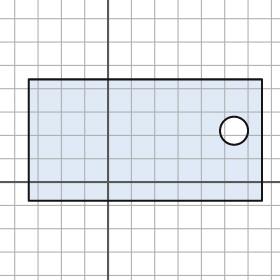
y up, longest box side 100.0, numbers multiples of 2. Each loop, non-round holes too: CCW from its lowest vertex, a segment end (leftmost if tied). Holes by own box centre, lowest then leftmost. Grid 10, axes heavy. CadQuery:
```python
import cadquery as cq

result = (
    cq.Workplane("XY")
    .moveTo(-34.0, -8.0)
    .lineTo(66.0, -8.0)
    .lineTo(66.0, 44.0)
    .lineTo(-34.0, 44.0)
    .close()
    .moveTo(54.0, 22.0)
    .circle(6.0)
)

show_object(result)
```